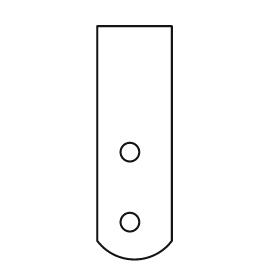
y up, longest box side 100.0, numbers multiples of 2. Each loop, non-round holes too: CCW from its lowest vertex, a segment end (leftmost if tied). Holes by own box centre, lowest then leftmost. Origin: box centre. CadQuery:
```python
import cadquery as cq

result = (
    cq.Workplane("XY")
    .moveTo(-16.0, -42.0)
    .threePointArc((0.0, -50.0), (16.0, -42.0))
    .lineTo(16.0, 50.0)
    .lineTo(-16.0, 50.0)
    .close()
    .moveTo(-2.0, -34.0)
    .circle(4.0)
    .moveTo(-2.0, -4.0)
    .circle(4.0)
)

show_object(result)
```